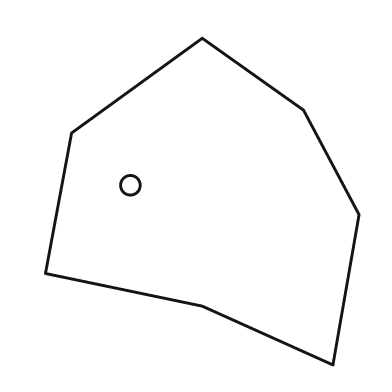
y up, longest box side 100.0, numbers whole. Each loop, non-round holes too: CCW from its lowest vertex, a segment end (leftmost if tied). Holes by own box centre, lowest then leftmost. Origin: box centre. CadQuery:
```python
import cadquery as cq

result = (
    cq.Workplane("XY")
    .moveTo(40.0, -50.0)
    .lineTo(48.0, -4.0)
    .lineTo(31.0, 28.0)
    .lineTo(0.0, 50.0)
    .lineTo(-40.0, 21.0)
    .lineTo(-48.0, -22.0)
    .lineTo(0.0, -32.0)
    .close()
    .moveTo(-22.0, 5.0)
    .circle(3.0)
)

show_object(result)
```